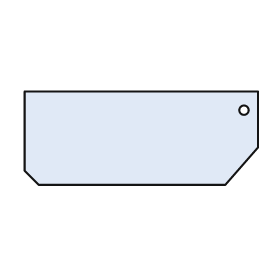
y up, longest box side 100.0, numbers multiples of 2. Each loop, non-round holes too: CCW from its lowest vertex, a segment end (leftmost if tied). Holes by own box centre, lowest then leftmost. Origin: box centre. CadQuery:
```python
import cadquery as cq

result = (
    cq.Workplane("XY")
    .moveTo(-44.0, -20.0)
    .lineTo(36.0, -20.0)
    .lineTo(50.0, -4.0)
    .lineTo(50.0, 20.0)
    .lineTo(-50.0, 20.0)
    .lineTo(-50.0, -14.0)
    .close()
    .moveTo(44.0, 12.0)
    .circle(2.0)
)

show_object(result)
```